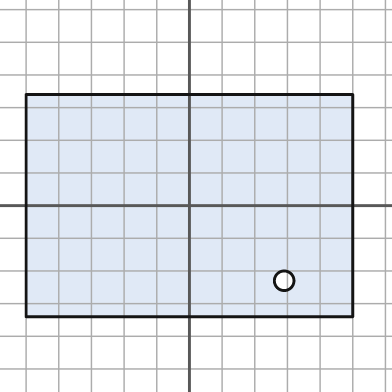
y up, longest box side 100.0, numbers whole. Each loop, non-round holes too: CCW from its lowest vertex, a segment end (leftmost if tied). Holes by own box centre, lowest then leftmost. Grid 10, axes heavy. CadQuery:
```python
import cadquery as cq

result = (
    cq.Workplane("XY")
    .moveTo(-50.0, -34.0)
    .lineTo(50.0, -34.0)
    .lineTo(50.0, 34.0)
    .lineTo(-50.0, 34.0)
    .close()
    .moveTo(29.0, -23.0)
    .circle(3.0)
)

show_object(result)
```